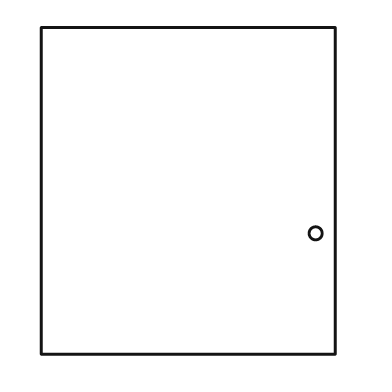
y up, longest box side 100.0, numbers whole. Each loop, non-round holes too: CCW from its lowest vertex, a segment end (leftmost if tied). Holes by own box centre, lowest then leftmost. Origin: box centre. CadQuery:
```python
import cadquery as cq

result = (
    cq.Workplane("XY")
    .moveTo(-45.0, -50.0)
    .lineTo(45.0, -50.0)
    .lineTo(45.0, 50.0)
    .lineTo(-45.0, 50.0)
    .close()
    .moveTo(39.0, -13.0)
    .circle(2.0)
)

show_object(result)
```